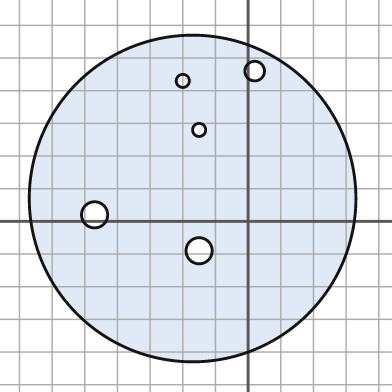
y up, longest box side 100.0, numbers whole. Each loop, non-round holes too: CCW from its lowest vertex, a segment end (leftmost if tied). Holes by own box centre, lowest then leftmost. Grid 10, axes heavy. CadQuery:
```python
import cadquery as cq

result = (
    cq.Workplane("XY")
    .moveTo(-17.0, 7.0)
    .circle(50.0)
    .moveTo(-15.0, -9.0)
    .circle(4.0)
    .moveTo(-47.0, 2.0)
    .circle(4.0)
    .moveTo(-15.0, 28.0)
    .circle(2.0)
    .moveTo(-20.0, 43.0)
    .circle(2.0)
    .moveTo(2.0, 46.0)
    .circle(3.0)
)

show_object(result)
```